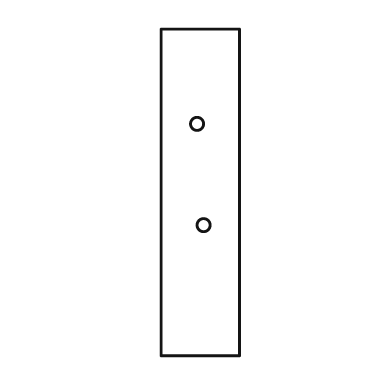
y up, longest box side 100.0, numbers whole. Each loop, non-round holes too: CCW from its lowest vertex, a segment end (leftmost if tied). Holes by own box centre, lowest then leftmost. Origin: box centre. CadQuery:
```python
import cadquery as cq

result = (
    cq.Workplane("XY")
    .moveTo(-12.0, -50.0)
    .lineTo(12.0, -50.0)
    .lineTo(12.0, 50.0)
    .lineTo(-12.0, 50.0)
    .close()
    .moveTo(1.0, -10.0)
    .circle(2.0)
    .moveTo(-1.0, 21.0)
    .circle(2.0)
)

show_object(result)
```